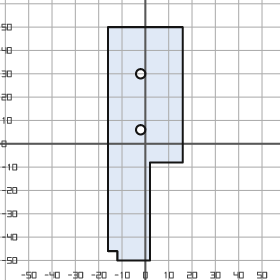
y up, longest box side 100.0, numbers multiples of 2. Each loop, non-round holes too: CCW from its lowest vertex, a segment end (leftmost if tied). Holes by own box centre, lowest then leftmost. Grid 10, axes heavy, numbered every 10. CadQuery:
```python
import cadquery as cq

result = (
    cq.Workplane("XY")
    .moveTo(-12.0, -50.0)
    .lineTo(2.0, -50.0)
    .lineTo(2.0, -8.0)
    .lineTo(16.0, -8.0)
    .lineTo(16.0, 50.0)
    .lineTo(-16.0, 50.0)
    .lineTo(-16.0, -46.0)
    .lineTo(-12.0, -46.0)
    .close()
    .moveTo(-2.0, 6.0)
    .circle(2.0)
    .moveTo(-2.0, 30.0)
    .circle(2.0)
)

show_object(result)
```